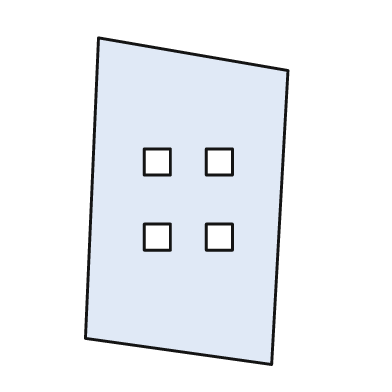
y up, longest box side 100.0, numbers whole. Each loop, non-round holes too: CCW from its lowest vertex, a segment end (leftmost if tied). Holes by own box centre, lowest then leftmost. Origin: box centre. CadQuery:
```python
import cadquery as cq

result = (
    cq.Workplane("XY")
    .moveTo(26.0, -50.0)
    .lineTo(31.0, 40.0)
    .lineTo(-27.0, 50.0)
    .lineTo(-31.0, -42.0)
    .close()
    .moveTo(-13.0, -15.0)
    .lineTo(-5.0, -15.0)
    .lineTo(-5.0, -7.0)
    .lineTo(-13.0, -7.0)
    .close()
    .moveTo(6.0, -15.0)
    .lineTo(14.0, -15.0)
    .lineTo(14.0, -7.0)
    .lineTo(6.0, -7.0)
    .close()
    .moveTo(-13.0, 8.0)
    .lineTo(-5.0, 8.0)
    .lineTo(-5.0, 16.0)
    .lineTo(-13.0, 16.0)
    .close()
    .moveTo(6.0, 8.0)
    .lineTo(14.0, 8.0)
    .lineTo(14.0, 16.0)
    .lineTo(6.0, 16.0)
    .close()
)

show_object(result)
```